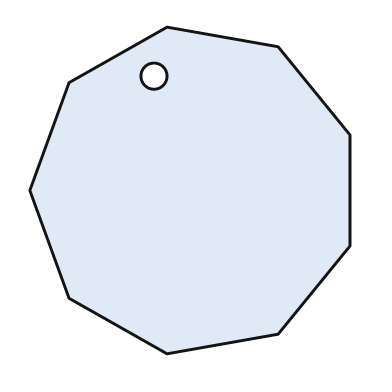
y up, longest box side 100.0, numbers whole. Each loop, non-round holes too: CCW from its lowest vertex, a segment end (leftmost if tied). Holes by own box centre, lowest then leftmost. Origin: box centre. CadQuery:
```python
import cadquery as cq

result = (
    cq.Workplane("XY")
    .moveTo(-7.0, -50.0)
    .lineTo(27.0, -44.0)
    .lineTo(49.0, -17.0)
    .lineTo(49.0, 17.0)
    .lineTo(27.0, 44.0)
    .lineTo(-7.0, 50.0)
    .lineTo(-37.0, 33.0)
    .lineTo(-49.0, 0.0)
    .lineTo(-37.0, -33.0)
    .close()
    .moveTo(-11.0, 35.0)
    .circle(4.0)
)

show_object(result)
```